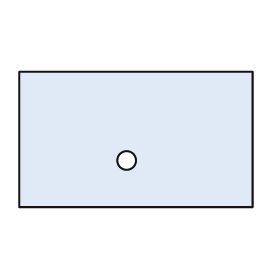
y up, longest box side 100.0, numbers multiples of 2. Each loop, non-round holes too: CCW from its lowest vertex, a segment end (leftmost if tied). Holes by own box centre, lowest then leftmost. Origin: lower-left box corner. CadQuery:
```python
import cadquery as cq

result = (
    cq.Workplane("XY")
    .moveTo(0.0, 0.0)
    .lineTo(100.0, 0.0)
    .lineTo(100.0, 58.0)
    .lineTo(0.0, 58.0)
    .close()
    .moveTo(46.0, 20.0)
    .circle(4.0)
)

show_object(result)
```